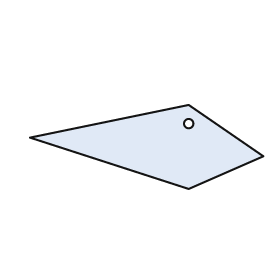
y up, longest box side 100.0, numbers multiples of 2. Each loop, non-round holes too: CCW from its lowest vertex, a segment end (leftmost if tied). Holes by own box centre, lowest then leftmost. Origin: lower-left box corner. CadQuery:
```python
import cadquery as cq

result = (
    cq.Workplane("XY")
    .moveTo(68.0, 0.0)
    .lineTo(100.0, 14.0)
    .lineTo(68.0, 36.0)
    .lineTo(0.0, 22.0)
    .close()
    .moveTo(68.0, 28.0)
    .circle(2.0)
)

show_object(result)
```